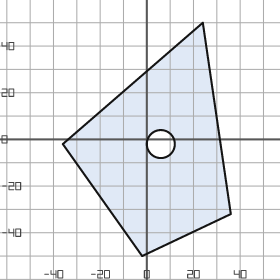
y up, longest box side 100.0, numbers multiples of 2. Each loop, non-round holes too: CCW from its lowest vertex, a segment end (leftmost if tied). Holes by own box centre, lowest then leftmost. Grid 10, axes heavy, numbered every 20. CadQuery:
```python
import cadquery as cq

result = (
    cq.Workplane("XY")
    .moveTo(-2.0, -50.0)
    .lineTo(36.0, -32.0)
    .lineTo(24.0, 50.0)
    .lineTo(-36.0, -2.0)
    .close()
    .moveTo(6.0, -2.0)
    .circle(6.0)
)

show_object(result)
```